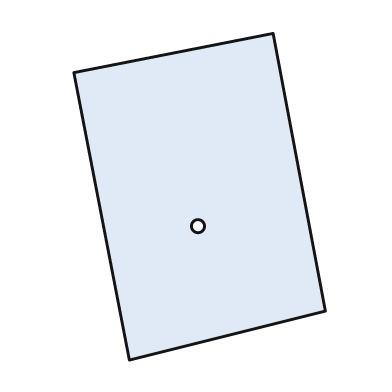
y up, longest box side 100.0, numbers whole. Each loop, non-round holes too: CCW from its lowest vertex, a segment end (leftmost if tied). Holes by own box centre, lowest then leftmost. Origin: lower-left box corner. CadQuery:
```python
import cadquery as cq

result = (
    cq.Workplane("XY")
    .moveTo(17.0, 0.0)
    .lineTo(77.0, 15.0)
    .lineTo(61.0, 100.0)
    .lineTo(0.0, 88.0)
    .close()
    .moveTo(38.0, 41.0)
    .circle(2.0)
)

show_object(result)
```